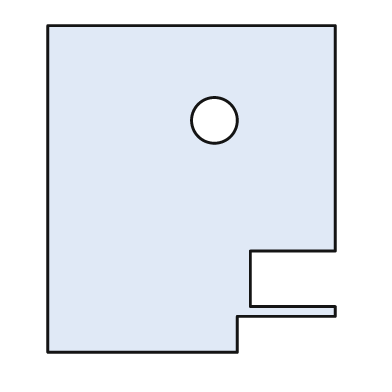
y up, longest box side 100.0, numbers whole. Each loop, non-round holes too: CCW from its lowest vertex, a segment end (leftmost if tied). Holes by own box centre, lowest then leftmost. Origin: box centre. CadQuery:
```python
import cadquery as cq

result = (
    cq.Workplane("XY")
    .moveTo(-44.0, -50.0)
    .lineTo(14.0, -50.0)
    .lineTo(14.0, -39.0)
    .lineTo(44.0, -39.0)
    .lineTo(44.0, -36.0)
    .lineTo(18.0, -36.0)
    .lineTo(18.0, -19.0)
    .lineTo(44.0, -19.0)
    .lineTo(44.0, 50.0)
    .lineTo(-44.0, 50.0)
    .close()
    .moveTo(7.0, 21.0)
    .circle(7.0)
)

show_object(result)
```